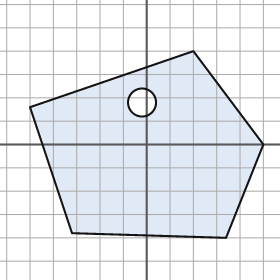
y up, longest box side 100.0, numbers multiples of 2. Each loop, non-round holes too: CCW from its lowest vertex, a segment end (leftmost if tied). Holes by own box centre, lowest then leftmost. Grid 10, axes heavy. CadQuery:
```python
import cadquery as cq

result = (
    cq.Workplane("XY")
    .moveTo(34.0, -40.0)
    .lineTo(50.0, 0.0)
    .lineTo(20.0, 40.0)
    .lineTo(-50.0, 16.0)
    .lineTo(-32.0, -38.0)
    .close()
    .moveTo(-2.0, 18.0)
    .circle(6.0)
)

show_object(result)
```